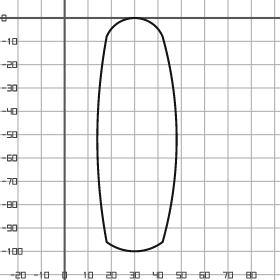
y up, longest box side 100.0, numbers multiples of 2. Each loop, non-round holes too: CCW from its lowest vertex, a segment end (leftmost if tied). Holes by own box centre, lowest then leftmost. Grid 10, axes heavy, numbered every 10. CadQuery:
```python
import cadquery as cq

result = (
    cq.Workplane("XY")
    .moveTo(18.0, -96.0)
    .threePointArc((30.0, -100.0), (42.0, -96.0))
    .threePointArc((48.0, -52.0), (42.0, -8.0))
    .threePointArc((30.0, 0.0), (18.0, -8.0))
    .threePointArc((14.0, -52.0), (18.0, -96.0))
    .close()
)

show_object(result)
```